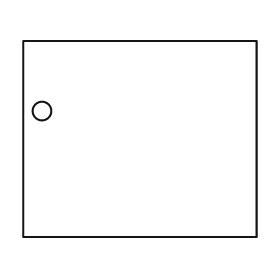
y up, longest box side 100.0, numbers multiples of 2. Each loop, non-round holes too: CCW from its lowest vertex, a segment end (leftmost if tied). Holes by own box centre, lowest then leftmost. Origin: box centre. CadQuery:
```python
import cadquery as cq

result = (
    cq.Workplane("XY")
    .moveTo(-50.0, -42.0)
    .lineTo(50.0, -42.0)
    .lineTo(50.0, 42.0)
    .lineTo(-50.0, 42.0)
    .close()
    .moveTo(-42.0, 12.0)
    .circle(4.0)
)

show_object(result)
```